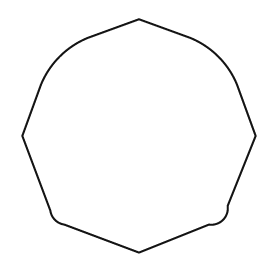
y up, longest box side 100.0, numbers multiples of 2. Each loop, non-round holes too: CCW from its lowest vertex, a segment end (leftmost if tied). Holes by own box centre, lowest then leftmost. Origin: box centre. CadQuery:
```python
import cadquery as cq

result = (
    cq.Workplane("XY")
    .moveTo(0.0, -50.0)
    .lineTo(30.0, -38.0)
    .threePointArc((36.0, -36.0), (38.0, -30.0))
    .lineTo(50.0, 0.0)
    .lineTo(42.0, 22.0)
    .threePointArc((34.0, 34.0), (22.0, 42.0))
    .lineTo(0.0, 50.0)
    .lineTo(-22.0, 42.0)
    .threePointArc((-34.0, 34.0), (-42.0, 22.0))
    .lineTo(-50.0, 0.0)
    .lineTo(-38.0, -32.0)
    .threePointArc((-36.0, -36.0), (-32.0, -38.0))
    .close()
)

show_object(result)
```